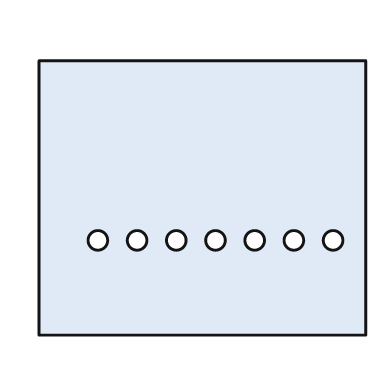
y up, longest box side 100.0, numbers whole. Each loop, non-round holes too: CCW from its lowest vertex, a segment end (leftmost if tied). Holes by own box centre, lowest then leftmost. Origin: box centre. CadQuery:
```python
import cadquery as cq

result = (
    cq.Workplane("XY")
    .moveTo(-50.0, -42.0)
    .lineTo(50.0, -42.0)
    .lineTo(50.0, 42.0)
    .lineTo(-50.0, 42.0)
    .close()
    .moveTo(-32.0, -13.0)
    .circle(3.0)
    .moveTo(-20.0, -13.0)
    .circle(3.0)
    .moveTo(-8.0, -13.0)
    .circle(3.0)
    .moveTo(4.0, -13.0)
    .circle(3.0)
    .moveTo(16.0, -13.0)
    .circle(3.0)
    .moveTo(28.0, -13.0)
    .circle(3.0)
    .moveTo(40.0, -13.0)
    .circle(3.0)
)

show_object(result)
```